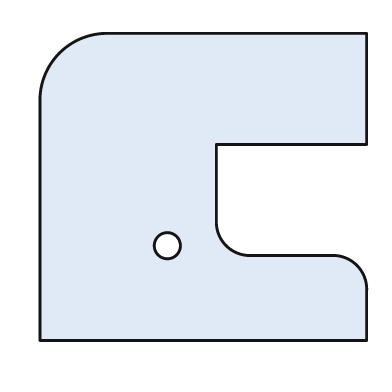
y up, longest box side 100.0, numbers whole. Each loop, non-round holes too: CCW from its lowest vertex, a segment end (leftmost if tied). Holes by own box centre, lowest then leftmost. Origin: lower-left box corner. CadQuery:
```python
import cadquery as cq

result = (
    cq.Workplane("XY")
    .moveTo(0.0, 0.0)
    .lineTo(100.0, 0.0)
    .lineTo(100.0, 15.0)
    .threePointArc((97.0, 23.0), (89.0, 26.0))
    .lineTo(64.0, 26.0)
    .threePointArc((57.0, 29.0), (54.0, 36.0))
    .lineTo(54.0, 60.0)
    .lineTo(100.0, 60.0)
    .lineTo(100.0, 94.0)
    .lineTo(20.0, 94.0)
    .threePointArc((6.0, 88.0), (0.0, 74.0))
    .close()
    .moveTo(39.0, 29.0)
    .circle(4.0)
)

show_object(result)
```